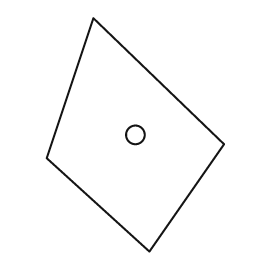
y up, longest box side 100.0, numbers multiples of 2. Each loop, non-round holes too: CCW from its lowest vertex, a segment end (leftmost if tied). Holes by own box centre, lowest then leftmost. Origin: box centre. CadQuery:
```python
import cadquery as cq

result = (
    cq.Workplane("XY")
    .moveTo(6.0, -50.0)
    .lineTo(38.0, -4.0)
    .lineTo(-18.0, 50.0)
    .lineTo(-38.0, -10.0)
    .close()
    .moveTo(0.0, 0.0)
    .circle(4.0)
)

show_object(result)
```